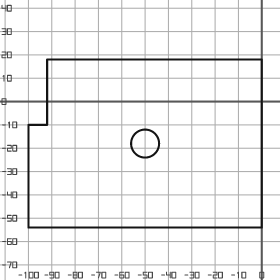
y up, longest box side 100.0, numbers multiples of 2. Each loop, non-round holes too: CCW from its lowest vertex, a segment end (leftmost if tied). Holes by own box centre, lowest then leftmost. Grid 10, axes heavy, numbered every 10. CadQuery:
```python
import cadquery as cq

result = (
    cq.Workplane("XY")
    .moveTo(-100.0, -54.0)
    .lineTo(0.0, -54.0)
    .lineTo(0.0, 18.0)
    .lineTo(-92.0, 18.0)
    .lineTo(-92.0, -10.0)
    .lineTo(-100.0, -10.0)
    .close()
    .moveTo(-50.0, -18.0)
    .circle(6.0)
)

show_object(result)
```